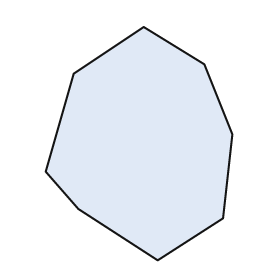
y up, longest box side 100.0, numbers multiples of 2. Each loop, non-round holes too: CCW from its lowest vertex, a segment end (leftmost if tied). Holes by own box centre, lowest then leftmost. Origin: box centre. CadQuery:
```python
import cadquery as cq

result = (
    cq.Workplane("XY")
    .moveTo(8.0, -50.0)
    .lineTo(36.0, -32.0)
    .lineTo(40.0, 4.0)
    .lineTo(28.0, 34.0)
    .lineTo(2.0, 50.0)
    .lineTo(-28.0, 30.0)
    .lineTo(-40.0, -12.0)
    .lineTo(-26.0, -28.0)
    .close()
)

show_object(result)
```